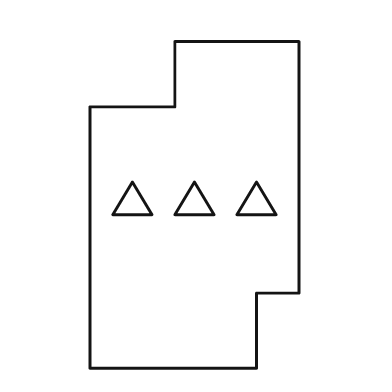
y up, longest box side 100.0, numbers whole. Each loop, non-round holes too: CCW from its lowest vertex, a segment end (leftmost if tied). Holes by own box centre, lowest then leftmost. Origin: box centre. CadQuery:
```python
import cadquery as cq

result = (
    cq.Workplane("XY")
    .moveTo(-32.0, -50.0)
    .lineTo(19.0, -50.0)
    .lineTo(19.0, -27.0)
    .lineTo(32.0, -27.0)
    .lineTo(32.0, 50.0)
    .lineTo(-6.0, 50.0)
    .lineTo(-6.0, 30.0)
    .lineTo(-32.0, 30.0)
    .close()
    .moveTo(-25.0, -3.0)
    .lineTo(-13.0, -3.0)
    .lineTo(-19.0, 7.0)
    .close()
    .moveTo(-6.0, -3.0)
    .lineTo(6.0, -3.0)
    .lineTo(0.0, 7.0)
    .close()
    .moveTo(13.0, -3.0)
    .lineTo(25.0, -3.0)
    .lineTo(19.0, 7.0)
    .close()
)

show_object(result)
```